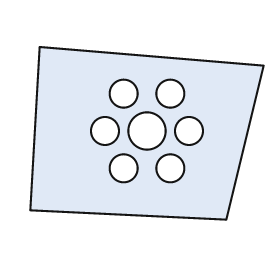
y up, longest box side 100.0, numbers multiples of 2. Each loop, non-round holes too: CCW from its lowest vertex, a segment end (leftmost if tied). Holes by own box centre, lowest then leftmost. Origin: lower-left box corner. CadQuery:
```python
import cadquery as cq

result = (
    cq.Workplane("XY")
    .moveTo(84.0, 0.0)
    .lineTo(100.0, 66.0)
    .lineTo(4.0, 74.0)
    .lineTo(0.0, 4.0)
    .close()
    .moveTo(40.0, 22.0)
    .circle(6.0)
    .moveTo(60.0, 22.0)
    .circle(6.0)
    .moveTo(32.0, 38.0)
    .circle(6.0)
    .moveTo(50.0, 38.0)
    .circle(8.0)
    .moveTo(68.0, 38.0)
    .circle(6.0)
    .moveTo(40.0, 54.0)
    .circle(6.0)
    .moveTo(60.0, 54.0)
    .circle(6.0)
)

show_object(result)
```